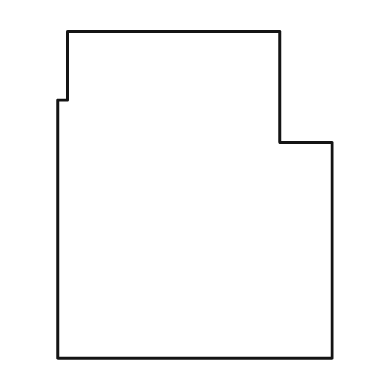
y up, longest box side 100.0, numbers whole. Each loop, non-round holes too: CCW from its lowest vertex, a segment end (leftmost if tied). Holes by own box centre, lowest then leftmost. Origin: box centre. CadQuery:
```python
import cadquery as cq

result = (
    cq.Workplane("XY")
    .moveTo(-42.0, -50.0)
    .lineTo(42.0, -50.0)
    .lineTo(42.0, 16.0)
    .lineTo(26.0, 16.0)
    .lineTo(26.0, 50.0)
    .lineTo(-39.0, 50.0)
    .lineTo(-39.0, 29.0)
    .lineTo(-42.0, 29.0)
    .close()
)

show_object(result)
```